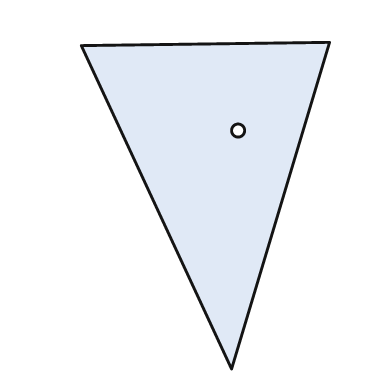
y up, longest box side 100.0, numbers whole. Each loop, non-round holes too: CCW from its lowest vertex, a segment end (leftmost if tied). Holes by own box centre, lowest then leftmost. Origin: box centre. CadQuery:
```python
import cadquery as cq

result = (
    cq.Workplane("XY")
    .moveTo(8.0, -50.0)
    .lineTo(38.0, 50.0)
    .lineTo(-38.0, 49.0)
    .close()
    .moveTo(10.0, 23.0)
    .circle(2.0)
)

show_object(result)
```